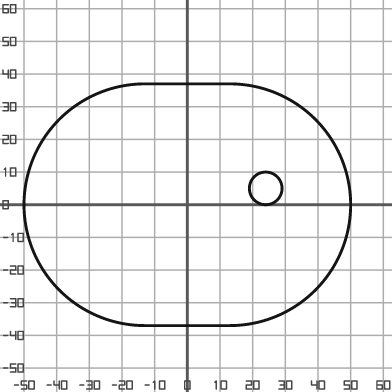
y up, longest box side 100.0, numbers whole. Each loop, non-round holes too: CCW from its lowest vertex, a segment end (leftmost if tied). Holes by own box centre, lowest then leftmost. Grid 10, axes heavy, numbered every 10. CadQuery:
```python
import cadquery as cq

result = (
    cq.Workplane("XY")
    .moveTo(-13.0, -37.0)
    .lineTo(13.0, -37.0)
    .threePointArc((50.0, 0.0), (13.0, 37.0))
    .lineTo(-13.0, 37.0)
    .threePointArc((-50.0, 0.0), (-13.0, -37.0))
    .close()
    .moveTo(24.0, 5.0)
    .circle(5.0)
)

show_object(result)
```